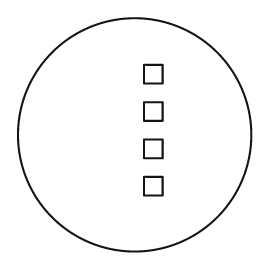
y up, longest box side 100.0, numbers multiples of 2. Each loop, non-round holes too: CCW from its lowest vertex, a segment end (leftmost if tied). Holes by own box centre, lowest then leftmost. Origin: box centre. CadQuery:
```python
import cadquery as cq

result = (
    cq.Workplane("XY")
    .moveTo(0.0, 0.0)
    .circle(50.0)
    .moveTo(4.0, -26.0)
    .lineTo(12.0, -26.0)
    .lineTo(12.0, -18.0)
    .lineTo(4.0, -18.0)
    .close()
    .moveTo(4.0, -10.0)
    .lineTo(12.0, -10.0)
    .lineTo(12.0, -2.0)
    .lineTo(4.0, -2.0)
    .close()
    .moveTo(4.0, 6.0)
    .lineTo(12.0, 6.0)
    .lineTo(12.0, 14.0)
    .lineTo(4.0, 14.0)
    .close()
    .moveTo(4.0, 22.0)
    .lineTo(12.0, 22.0)
    .lineTo(12.0, 30.0)
    .lineTo(4.0, 30.0)
    .close()
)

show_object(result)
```